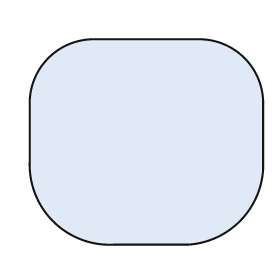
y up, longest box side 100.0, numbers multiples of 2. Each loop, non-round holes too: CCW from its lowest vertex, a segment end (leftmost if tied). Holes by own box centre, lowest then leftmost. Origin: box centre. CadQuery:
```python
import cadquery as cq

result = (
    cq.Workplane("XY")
    .moveTo(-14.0, -44.0)
    .lineTo(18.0, -44.0)
    .threePointArc((40.0, -34.0), (50.0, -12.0))
    .lineTo(50.0, 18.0)
    .threePointArc((42.0, 36.0), (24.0, 44.0))
    .lineTo(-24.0, 44.0)
    .threePointArc((-42.0, 36.0), (-50.0, 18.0))
    .lineTo(-50.0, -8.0)
    .threePointArc((-40.0, -34.0), (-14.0, -44.0))
    .close()
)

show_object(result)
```